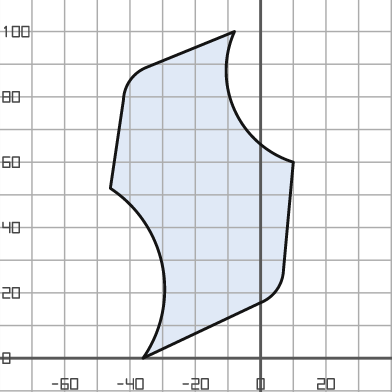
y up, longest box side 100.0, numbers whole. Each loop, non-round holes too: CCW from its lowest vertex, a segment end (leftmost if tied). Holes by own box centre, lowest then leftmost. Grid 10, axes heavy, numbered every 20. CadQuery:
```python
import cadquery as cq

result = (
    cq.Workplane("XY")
    .moveTo(-36.0, 0.0)
    .lineTo(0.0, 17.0)
    .threePointArc((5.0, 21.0), (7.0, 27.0))
    .lineTo(10.0, 60.0)
    .threePointArc((-8.0, 76.0), (-8.0, 100.0))
    .lineTo(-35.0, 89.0)
    .threePointArc((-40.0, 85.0), (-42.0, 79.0))
    .lineTo(-46.0, 52.0)
    .threePointArc((-30.0, 28.0), (-36.0, 0.0))
    .close()
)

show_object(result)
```